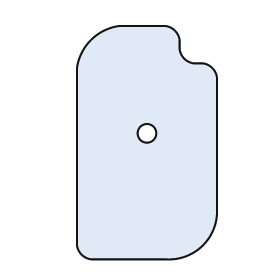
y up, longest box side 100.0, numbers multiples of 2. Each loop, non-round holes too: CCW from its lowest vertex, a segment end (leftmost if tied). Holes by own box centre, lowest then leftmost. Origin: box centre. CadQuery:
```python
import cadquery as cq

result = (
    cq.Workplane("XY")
    .moveTo(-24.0, -50.0)
    .lineTo(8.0, -50.0)
    .threePointArc((24.0, -44.0), (30.0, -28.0))
    .lineTo(30.0, 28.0)
    .threePointArc((28.0, 32.0), (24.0, 34.0))
    .lineTo(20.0, 34.0)
    .threePointArc((16.0, 36.0), (14.0, 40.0))
    .lineTo(14.0, 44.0)
    .threePointArc((12.0, 48.0), (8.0, 50.0))
    .lineTo(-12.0, 50.0)
    .threePointArc((-24.0, 44.0), (-30.0, 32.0))
    .lineTo(-30.0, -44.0)
    .threePointArc((-28.0, -48.0), (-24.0, -50.0))
    .close()
    .moveTo(0.0, 4.0)
    .circle(4.0)
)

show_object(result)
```